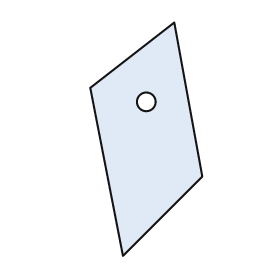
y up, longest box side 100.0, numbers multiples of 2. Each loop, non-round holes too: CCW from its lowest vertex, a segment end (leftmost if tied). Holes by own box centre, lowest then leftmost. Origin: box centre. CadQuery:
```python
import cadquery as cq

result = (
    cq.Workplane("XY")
    .moveTo(-10.0, -50.0)
    .lineTo(24.0, -16.0)
    .lineTo(12.0, 50.0)
    .lineTo(-24.0, 22.0)
    .close()
    .moveTo(0.0, 16.0)
    .circle(4.0)
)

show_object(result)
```